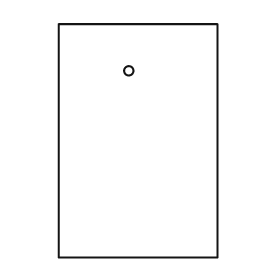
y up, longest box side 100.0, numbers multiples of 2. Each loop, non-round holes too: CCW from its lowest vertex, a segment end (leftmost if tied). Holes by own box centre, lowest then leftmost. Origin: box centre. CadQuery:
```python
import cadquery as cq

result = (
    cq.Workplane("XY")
    .moveTo(-34.0, -50.0)
    .lineTo(34.0, -50.0)
    .lineTo(34.0, 50.0)
    .lineTo(-34.0, 50.0)
    .close()
    .moveTo(-4.0, 30.0)
    .circle(2.0)
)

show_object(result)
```